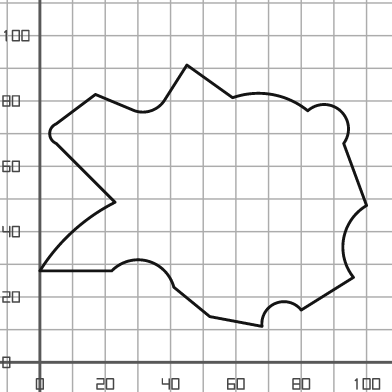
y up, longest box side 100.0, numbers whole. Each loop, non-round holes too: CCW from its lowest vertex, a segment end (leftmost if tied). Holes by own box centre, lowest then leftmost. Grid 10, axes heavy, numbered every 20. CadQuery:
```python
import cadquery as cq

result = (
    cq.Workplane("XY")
    .moveTo(68.0, 11.0)
    .threePointArc((72.0, 18.0), (80.0, 16.0))
    .lineTo(96.0, 26.0)
    .threePointArc((93.0, 38.0), (100.0, 48.0))
    .lineTo(93.0, 67.0)
    .threePointArc((92.0, 77.0), (82.0, 77.0))
    .threePointArc((71.0, 82.0), (59.0, 81.0))
    .lineTo(45.0, 91.0)
    .lineTo(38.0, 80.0)
    .threePointArc((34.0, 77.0), (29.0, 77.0))
    .lineTo(17.0, 82.0)
    .lineTo(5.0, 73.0)
    .threePointArc((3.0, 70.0), (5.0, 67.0))
    .lineTo(23.0, 49.0)
    .threePointArc((10.0, 40.0), (0.0, 28.0))
    .lineTo(22.0, 28.0)
    .threePointArc((33.0, 31.0), (41.0, 23.0))
    .lineTo(52.0, 14.0)
    .close()
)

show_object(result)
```